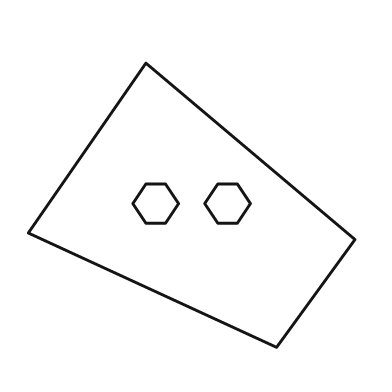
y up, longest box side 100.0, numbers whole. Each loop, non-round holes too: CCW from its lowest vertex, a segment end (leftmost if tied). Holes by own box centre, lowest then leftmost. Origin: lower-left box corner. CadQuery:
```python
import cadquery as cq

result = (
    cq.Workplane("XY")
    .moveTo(76.0, 0.0)
    .lineTo(100.0, 33.0)
    .lineTo(36.0, 87.0)
    .lineTo(0.0, 35.0)
    .close()
    .moveTo(36.0, 38.0)
    .lineTo(42.0, 38.0)
    .lineTo(46.0, 44.0)
    .lineTo(42.0, 50.0)
    .lineTo(36.0, 50.0)
    .lineTo(32.0, 44.0)
    .close()
    .moveTo(58.0, 38.0)
    .lineTo(64.0, 38.0)
    .lineTo(68.0, 44.0)
    .lineTo(64.0, 50.0)
    .lineTo(58.0, 50.0)
    .lineTo(54.0, 44.0)
    .close()
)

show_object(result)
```